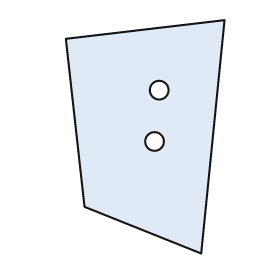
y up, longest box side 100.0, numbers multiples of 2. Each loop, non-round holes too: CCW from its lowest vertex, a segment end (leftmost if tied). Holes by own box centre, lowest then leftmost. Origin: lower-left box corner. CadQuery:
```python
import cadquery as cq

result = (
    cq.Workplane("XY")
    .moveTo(58.0, 0.0)
    .lineTo(68.0, 100.0)
    .lineTo(0.0, 92.0)
    .lineTo(8.0, 20.0)
    .close()
    .moveTo(38.0, 48.0)
    .circle(4.0)
    .moveTo(40.0, 70.0)
    .circle(4.0)
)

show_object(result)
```